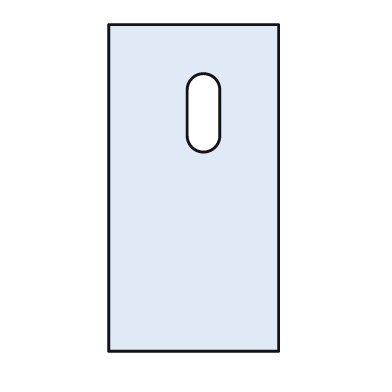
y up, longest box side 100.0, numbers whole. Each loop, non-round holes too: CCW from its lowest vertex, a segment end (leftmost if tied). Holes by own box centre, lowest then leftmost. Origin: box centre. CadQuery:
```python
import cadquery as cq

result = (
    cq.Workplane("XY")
    .moveTo(-26.0, -50.0)
    .lineTo(26.0, -50.0)
    .lineTo(26.0, 50.0)
    .lineTo(-26.0, 50.0)
    .close()
    .moveTo(-2.0, 16.0)
    .threePointArc((3.0, 11.0), (8.0, 16.0))
    .lineTo(8.0, 30.0)
    .threePointArc((3.0, 35.0), (-2.0, 30.0))
    .close()
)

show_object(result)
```